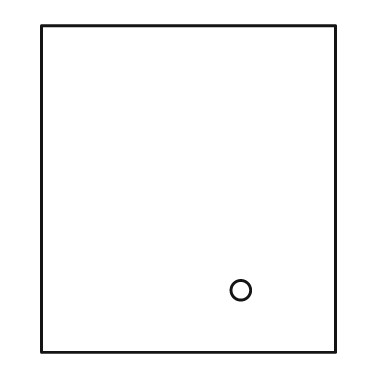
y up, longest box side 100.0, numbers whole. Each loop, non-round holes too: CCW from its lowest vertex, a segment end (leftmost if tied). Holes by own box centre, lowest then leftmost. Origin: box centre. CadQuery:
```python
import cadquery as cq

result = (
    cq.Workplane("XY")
    .moveTo(-45.0, -50.0)
    .lineTo(45.0, -50.0)
    .lineTo(45.0, 50.0)
    .lineTo(-45.0, 50.0)
    .close()
    .moveTo(16.0, -31.0)
    .circle(3.0)
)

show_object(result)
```